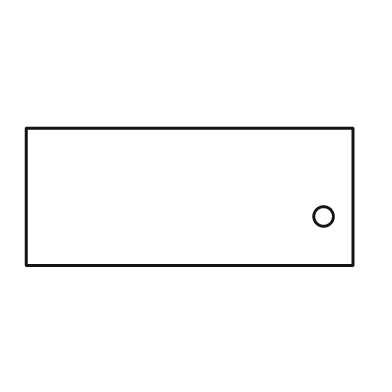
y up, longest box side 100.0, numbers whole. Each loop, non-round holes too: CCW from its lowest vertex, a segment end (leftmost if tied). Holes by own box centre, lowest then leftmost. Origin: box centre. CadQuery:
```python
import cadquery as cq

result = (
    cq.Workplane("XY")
    .moveTo(-50.0, -21.0)
    .lineTo(50.0, -21.0)
    .lineTo(50.0, 21.0)
    .lineTo(-50.0, 21.0)
    .close()
    .moveTo(41.0, -6.0)
    .circle(3.0)
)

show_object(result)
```